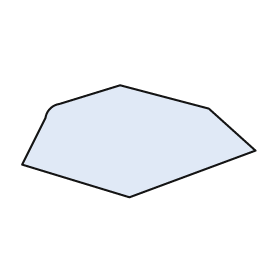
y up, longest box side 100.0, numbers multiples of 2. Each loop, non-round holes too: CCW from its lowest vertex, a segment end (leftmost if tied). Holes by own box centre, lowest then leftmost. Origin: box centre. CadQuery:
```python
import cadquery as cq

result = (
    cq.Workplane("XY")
    .moveTo(-4.0, -24.0)
    .lineTo(50.0, -4.0)
    .lineTo(30.0, 14.0)
    .lineTo(-8.0, 24.0)
    .lineTo(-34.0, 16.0)
    .threePointArc((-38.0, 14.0), (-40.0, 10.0))
    .lineTo(-50.0, -10.0)
    .close()
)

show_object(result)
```